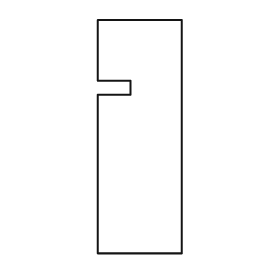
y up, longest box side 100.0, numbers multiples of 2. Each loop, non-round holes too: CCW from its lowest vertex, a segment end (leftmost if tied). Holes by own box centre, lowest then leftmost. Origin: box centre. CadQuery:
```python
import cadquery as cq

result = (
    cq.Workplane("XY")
    .moveTo(-18.0, -50.0)
    .lineTo(18.0, -50.0)
    .lineTo(18.0, 50.0)
    .lineTo(-18.0, 50.0)
    .lineTo(-18.0, 24.0)
    .lineTo(-4.0, 24.0)
    .lineTo(-4.0, 18.0)
    .lineTo(-18.0, 18.0)
    .close()
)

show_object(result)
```